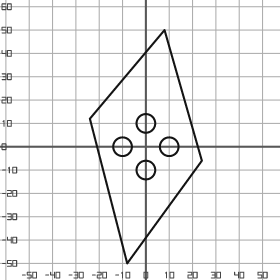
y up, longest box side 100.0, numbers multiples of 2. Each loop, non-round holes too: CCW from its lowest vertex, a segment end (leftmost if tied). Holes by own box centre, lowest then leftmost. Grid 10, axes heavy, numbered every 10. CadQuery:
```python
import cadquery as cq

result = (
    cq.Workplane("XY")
    .moveTo(-8.0, -50.0)
    .lineTo(24.0, -6.0)
    .lineTo(8.0, 50.0)
    .lineTo(-24.0, 12.0)
    .close()
    .moveTo(0.0, -10.0)
    .circle(4.0)
    .moveTo(-10.0, 0.0)
    .circle(4.0)
    .moveTo(10.0, 0.0)
    .circle(4.0)
    .moveTo(0.0, 10.0)
    .circle(4.0)
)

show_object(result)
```